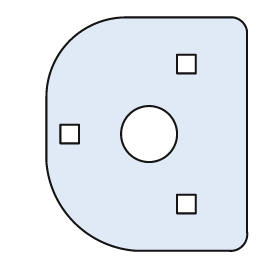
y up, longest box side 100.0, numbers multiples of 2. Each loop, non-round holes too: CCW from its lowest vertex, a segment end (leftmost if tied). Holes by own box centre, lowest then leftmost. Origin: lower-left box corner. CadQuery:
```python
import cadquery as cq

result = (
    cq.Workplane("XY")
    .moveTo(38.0, 0.0)
    .lineTo(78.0, 0.0)
    .threePointArc((84.0, 2.0), (86.0, 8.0))
    .lineTo(86.0, 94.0)
    .threePointArc((84.0, 98.0), (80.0, 100.0))
    .lineTo(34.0, 100.0)
    .threePointArc((10.0, 90.0), (0.0, 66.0))
    .lineTo(0.0, 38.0)
    .threePointArc((12.0, 12.0), (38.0, 0.0))
    .close()
    .moveTo(56.0, 16.0)
    .lineTo(64.0, 16.0)
    .lineTo(64.0, 24.0)
    .lineTo(56.0, 24.0)
    .close()
    .moveTo(6.0, 46.0)
    .lineTo(14.0, 46.0)
    .lineTo(14.0, 54.0)
    .lineTo(6.0, 54.0)
    .close()
    .moveTo(44.0, 50.0)
    .circle(12.0)
    .moveTo(56.0, 76.0)
    .lineTo(64.0, 76.0)
    .lineTo(64.0, 84.0)
    .lineTo(56.0, 84.0)
    .close()
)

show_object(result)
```